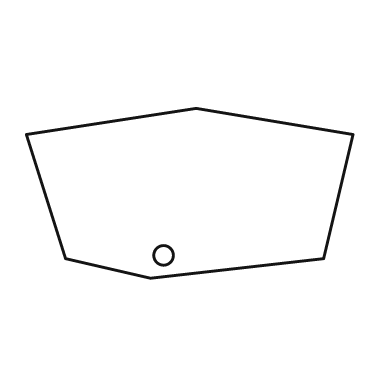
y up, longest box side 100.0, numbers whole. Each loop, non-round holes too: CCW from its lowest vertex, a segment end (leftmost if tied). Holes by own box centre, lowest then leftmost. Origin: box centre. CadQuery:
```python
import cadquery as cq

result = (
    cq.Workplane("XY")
    .moveTo(-12.0, -26.0)
    .lineTo(41.0, -20.0)
    .lineTo(50.0, 18.0)
    .lineTo(2.0, 26.0)
    .lineTo(-50.0, 18.0)
    .lineTo(-38.0, -20.0)
    .close()
    .moveTo(-8.0, -19.0)
    .circle(3.0)
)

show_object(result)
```